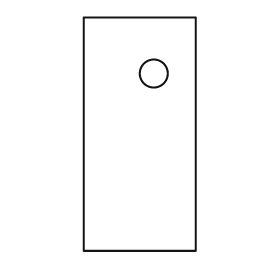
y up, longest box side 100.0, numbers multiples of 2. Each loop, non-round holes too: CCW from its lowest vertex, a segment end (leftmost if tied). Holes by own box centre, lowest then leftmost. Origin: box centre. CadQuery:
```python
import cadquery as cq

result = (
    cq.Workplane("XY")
    .moveTo(-24.0, -50.0)
    .lineTo(24.0, -50.0)
    .lineTo(24.0, 50.0)
    .lineTo(-24.0, 50.0)
    .close()
    .moveTo(6.0, 26.0)
    .circle(6.0)
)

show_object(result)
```